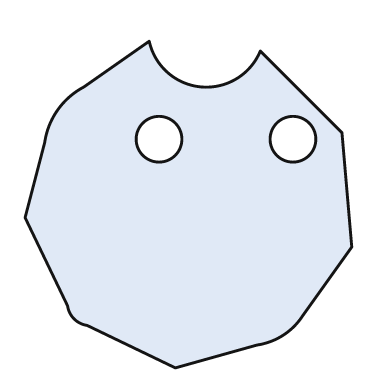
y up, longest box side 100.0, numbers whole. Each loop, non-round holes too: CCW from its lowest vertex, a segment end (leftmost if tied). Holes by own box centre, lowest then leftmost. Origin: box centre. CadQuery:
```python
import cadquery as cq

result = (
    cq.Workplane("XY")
    .moveTo(-4.0, -50.0)
    .lineTo(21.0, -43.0)
    .threePointArc((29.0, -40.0), (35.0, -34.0))
    .lineTo(50.0, -13.0)
    .lineTo(47.0, 22.0)
    .lineTo(22.0, 47.0)
    .threePointArc((4.0, 36.0), (-12.0, 50.0))
    .lineTo(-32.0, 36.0)
    .threePointArc((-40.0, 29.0), (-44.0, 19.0))
    .lineTo(-50.0, -4.0)
    .lineTo(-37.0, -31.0)
    .threePointArc((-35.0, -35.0), (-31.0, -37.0))
    .close()
    .moveTo(-9.0, 20.0)
    .circle(7.0)
    .moveTo(32.0, 20.0)
    .circle(7.0)
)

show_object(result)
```